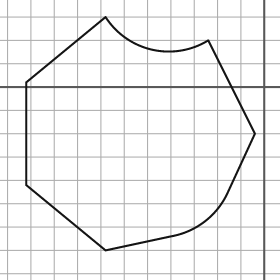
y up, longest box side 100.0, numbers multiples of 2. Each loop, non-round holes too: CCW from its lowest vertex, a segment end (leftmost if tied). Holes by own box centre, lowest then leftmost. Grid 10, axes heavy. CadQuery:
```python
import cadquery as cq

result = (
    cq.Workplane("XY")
    .moveTo(-68.0, -70.0)
    .lineTo(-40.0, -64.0)
    .threePointArc((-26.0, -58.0), (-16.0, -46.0))
    .lineTo(-4.0, -20.0)
    .lineTo(-24.0, 20.0)
    .threePointArc((-48.0, 16.0), (-68.0, 30.0))
    .lineTo(-102.0, 2.0)
    .lineTo(-102.0, -42.0)
    .close()
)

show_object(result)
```